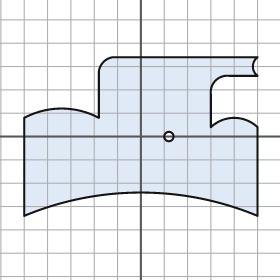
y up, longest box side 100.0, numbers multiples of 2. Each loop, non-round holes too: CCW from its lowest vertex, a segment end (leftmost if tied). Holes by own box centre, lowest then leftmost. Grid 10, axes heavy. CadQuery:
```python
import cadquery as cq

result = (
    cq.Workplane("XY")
    .moveTo(-50.0, -34.0)
    .threePointArc((0.0, -24.0), (50.0, -34.0))
    .lineTo(50.0, 4.0)
    .threePointArc((40.0, 8.0), (30.0, 4.0))
    .lineTo(30.0, 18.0)
    .threePointArc((32.0, 24.0), (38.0, 26.0))
    .lineTo(50.0, 26.0)
    .threePointArc((48.0, 30.0), (50.0, 34.0))
    .lineTo(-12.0, 34.0)
    .threePointArc((-16.0, 32.0), (-18.0, 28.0))
    .lineTo(-18.0, 8.0)
    .threePointArc((-34.0, 12.0), (-50.0, 8.0))
    .close()
    .moveTo(12.0, 0.0)
    .circle(2.0)
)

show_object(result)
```